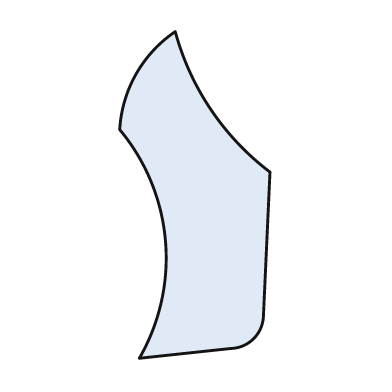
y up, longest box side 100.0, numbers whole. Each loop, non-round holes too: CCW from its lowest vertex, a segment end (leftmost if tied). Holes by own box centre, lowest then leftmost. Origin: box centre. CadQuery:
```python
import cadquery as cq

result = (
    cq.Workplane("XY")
    .moveTo(-17.0, -50.0)
    .lineTo(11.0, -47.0)
    .threePointArc((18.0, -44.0), (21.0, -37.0))
    .lineTo(23.0, 7.0)
    .threePointArc((5.0, 26.0), (-6.0, 50.0))
    .threePointArc((-18.0, 37.0), (-23.0, 20.0))
    .threePointArc((-9.0, -14.0), (-17.0, -50.0))
    .close()
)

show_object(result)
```